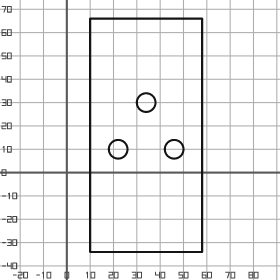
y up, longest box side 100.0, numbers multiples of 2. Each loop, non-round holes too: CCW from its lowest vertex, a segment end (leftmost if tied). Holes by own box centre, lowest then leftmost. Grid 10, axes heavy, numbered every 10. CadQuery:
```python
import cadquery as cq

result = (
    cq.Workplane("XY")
    .moveTo(10.0, -34.0)
    .lineTo(58.0, -34.0)
    .lineTo(58.0, 66.0)
    .lineTo(10.0, 66.0)
    .close()
    .moveTo(22.0, 10.0)
    .circle(4.0)
    .moveTo(46.0, 10.0)
    .circle(4.0)
    .moveTo(34.0, 30.0)
    .circle(4.0)
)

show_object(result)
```